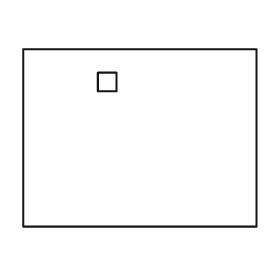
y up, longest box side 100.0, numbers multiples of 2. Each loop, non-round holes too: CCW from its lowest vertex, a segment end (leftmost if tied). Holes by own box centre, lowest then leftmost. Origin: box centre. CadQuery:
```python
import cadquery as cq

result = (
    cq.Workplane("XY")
    .moveTo(-50.0, -38.0)
    .lineTo(50.0, -38.0)
    .lineTo(50.0, 38.0)
    .lineTo(-50.0, 38.0)
    .close()
    .moveTo(-18.0, 20.0)
    .lineTo(-10.0, 20.0)
    .lineTo(-10.0, 28.0)
    .lineTo(-18.0, 28.0)
    .close()
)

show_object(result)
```